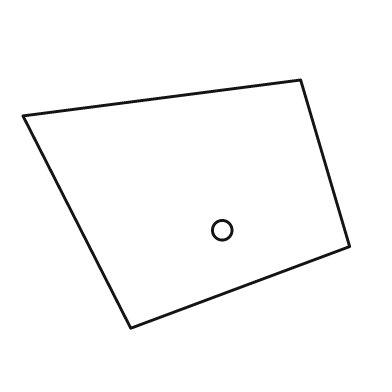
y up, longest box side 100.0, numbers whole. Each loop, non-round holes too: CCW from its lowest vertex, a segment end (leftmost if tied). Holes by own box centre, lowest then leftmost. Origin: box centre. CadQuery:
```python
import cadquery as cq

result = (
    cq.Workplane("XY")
    .moveTo(-17.0, -38.0)
    .lineTo(50.0, -13.0)
    .lineTo(35.0, 38.0)
    .lineTo(-50.0, 27.0)
    .close()
    .moveTo(11.0, -8.0)
    .circle(3.0)
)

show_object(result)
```